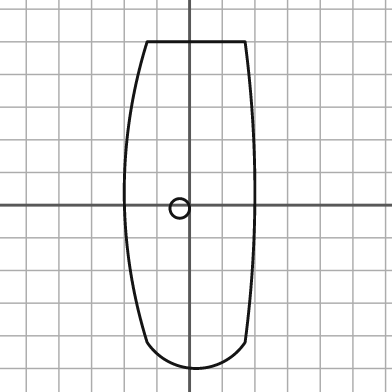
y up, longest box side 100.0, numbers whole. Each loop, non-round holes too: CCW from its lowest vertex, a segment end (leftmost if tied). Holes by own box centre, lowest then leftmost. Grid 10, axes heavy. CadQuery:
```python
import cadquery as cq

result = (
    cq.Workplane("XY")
    .moveTo(-13.0, -42.0)
    .threePointArc((2.0, -50.0), (17.0, -42.0))
    .threePointArc((20.0, 4.0), (17.0, 50.0))
    .lineTo(-13.0, 50.0)
    .threePointArc((-20.0, 4.0), (-13.0, -42.0))
    .close()
    .moveTo(-3.0, -1.0)
    .circle(3.0)
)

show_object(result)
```